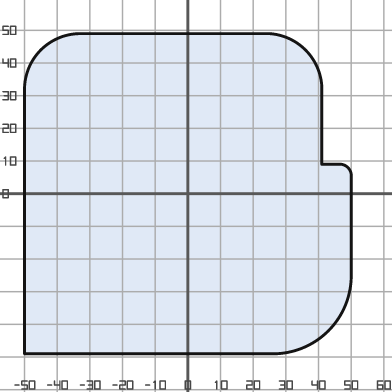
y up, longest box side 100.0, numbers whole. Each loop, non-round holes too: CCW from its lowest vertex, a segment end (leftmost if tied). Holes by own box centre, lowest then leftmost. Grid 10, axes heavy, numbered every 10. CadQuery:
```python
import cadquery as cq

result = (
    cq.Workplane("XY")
    .moveTo(-50.0, -49.0)
    .lineTo(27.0, -49.0)
    .threePointArc((43.0, -42.0), (50.0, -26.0))
    .lineTo(50.0, 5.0)
    .threePointArc((49.0, 8.0), (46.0, 9.0))
    .lineTo(41.0, 9.0)
    .lineTo(41.0, 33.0)
    .threePointArc((36.0, 44.0), (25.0, 49.0))
    .lineTo(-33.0, 49.0)
    .threePointArc((-45.0, 44.0), (-50.0, 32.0))
    .close()
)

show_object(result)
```